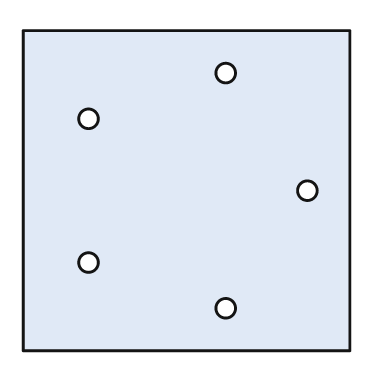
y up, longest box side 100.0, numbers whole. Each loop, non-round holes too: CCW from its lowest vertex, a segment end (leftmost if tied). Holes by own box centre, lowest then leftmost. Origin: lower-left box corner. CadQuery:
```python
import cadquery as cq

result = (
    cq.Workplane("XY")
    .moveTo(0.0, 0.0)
    .lineTo(100.0, 0.0)
    .lineTo(100.0, 98.0)
    .lineTo(0.0, 98.0)
    .close()
    .moveTo(62.0, 13.0)
    .circle(3.0)
    .moveTo(20.0, 27.0)
    .circle(3.0)
    .moveTo(87.0, 49.0)
    .circle(3.0)
    .moveTo(20.0, 71.0)
    .circle(3.0)
    .moveTo(62.0, 85.0)
    .circle(3.0)
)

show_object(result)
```